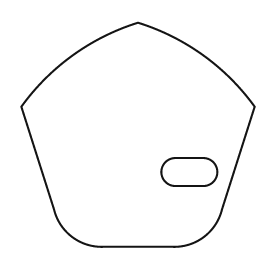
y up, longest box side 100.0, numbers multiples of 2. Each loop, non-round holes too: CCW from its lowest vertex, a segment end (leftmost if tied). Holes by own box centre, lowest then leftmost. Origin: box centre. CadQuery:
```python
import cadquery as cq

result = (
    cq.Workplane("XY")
    .moveTo(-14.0, -48.0)
    .lineTo(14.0, -48.0)
    .threePointArc((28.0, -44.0), (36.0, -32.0))
    .lineTo(50.0, 12.0)
    .threePointArc((28.0, 34.0), (0.0, 48.0))
    .threePointArc((-28.0, 34.0), (-50.0, 12.0))
    .lineTo(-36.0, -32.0)
    .threePointArc((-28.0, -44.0), (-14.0, -48.0))
    .close()
    .moveTo(16.0, -22.0)
    .lineTo(28.0, -22.0)
    .threePointArc((34.0, -16.0), (28.0, -10.0))
    .lineTo(16.0, -10.0)
    .threePointArc((10.0, -16.0), (16.0, -22.0))
    .close()
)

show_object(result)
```